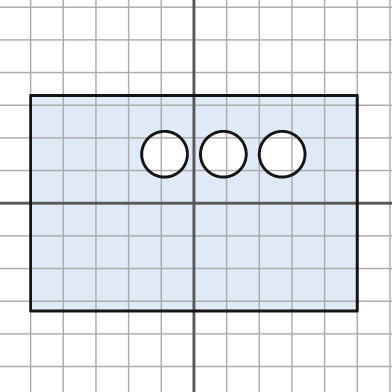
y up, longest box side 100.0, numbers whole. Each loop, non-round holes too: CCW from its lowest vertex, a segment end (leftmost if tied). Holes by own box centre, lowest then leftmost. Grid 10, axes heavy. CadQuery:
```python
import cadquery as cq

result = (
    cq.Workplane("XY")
    .moveTo(-50.0, -33.0)
    .lineTo(50.0, -33.0)
    .lineTo(50.0, 33.0)
    .lineTo(-50.0, 33.0)
    .close()
    .moveTo(-9.0, 15.0)
    .circle(7.0)
    .moveTo(9.0, 15.0)
    .circle(7.0)
    .moveTo(27.0, 15.0)
    .circle(7.0)
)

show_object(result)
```